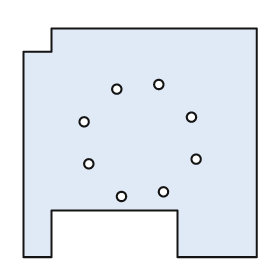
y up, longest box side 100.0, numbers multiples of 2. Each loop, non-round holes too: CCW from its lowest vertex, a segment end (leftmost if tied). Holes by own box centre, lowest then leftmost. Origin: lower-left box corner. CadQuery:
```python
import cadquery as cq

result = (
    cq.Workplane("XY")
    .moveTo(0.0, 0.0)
    .lineTo(12.0, 0.0)
    .lineTo(12.0, 20.0)
    .lineTo(66.0, 20.0)
    .lineTo(66.0, 0.0)
    .lineTo(100.0, 0.0)
    .lineTo(100.0, 98.0)
    .lineTo(12.0, 98.0)
    .lineTo(12.0, 88.0)
    .lineTo(0.0, 88.0)
    .close()
    .moveTo(42.0, 26.0)
    .circle(2.0)
    .moveTo(60.0, 28.0)
    .circle(2.0)
    .moveTo(28.0, 40.0)
    .circle(2.0)
    .moveTo(74.0, 42.0)
    .circle(2.0)
    .moveTo(26.0, 58.0)
    .circle(2.0)
    .moveTo(72.0, 60.0)
    .circle(2.0)
    .moveTo(40.0, 72.0)
    .circle(2.0)
    .moveTo(58.0, 74.0)
    .circle(2.0)
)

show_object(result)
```